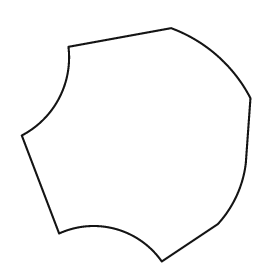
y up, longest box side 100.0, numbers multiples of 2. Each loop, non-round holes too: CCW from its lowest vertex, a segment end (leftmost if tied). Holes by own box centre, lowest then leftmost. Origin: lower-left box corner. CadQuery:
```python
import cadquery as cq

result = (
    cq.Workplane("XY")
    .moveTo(60.0, 0.0)
    .lineTo(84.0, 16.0)
    .threePointArc((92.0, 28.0), (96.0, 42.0))
    .lineTo(98.0, 70.0)
    .threePointArc((84.0, 88.0), (64.0, 100.0))
    .lineTo(20.0, 92.0)
    .threePointArc((16.0, 70.0), (0.0, 54.0))
    .lineTo(16.0, 12.0)
    .threePointArc((40.0, 14.0), (60.0, 0.0))
    .close()
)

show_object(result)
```